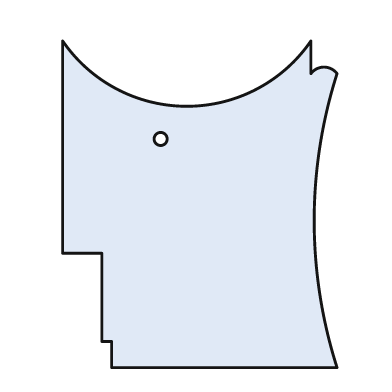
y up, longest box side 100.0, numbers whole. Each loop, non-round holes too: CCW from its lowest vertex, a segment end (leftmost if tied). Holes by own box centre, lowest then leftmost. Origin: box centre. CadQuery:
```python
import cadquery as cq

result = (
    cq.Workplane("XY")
    .moveTo(-27.0, -50.0)
    .lineTo(42.0, -50.0)
    .threePointArc((35.0, -5.0), (42.0, 40.0))
    .threePointArc((38.0, 42.0), (34.0, 40.0))
    .lineTo(34.0, 50.0)
    .threePointArc((-4.0, 30.0), (-42.0, 50.0))
    .lineTo(-42.0, -15.0)
    .lineTo(-30.0, -15.0)
    .lineTo(-30.0, -42.0)
    .lineTo(-27.0, -42.0)
    .close()
    .moveTo(-12.0, 20.0)
    .circle(2.0)
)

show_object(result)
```